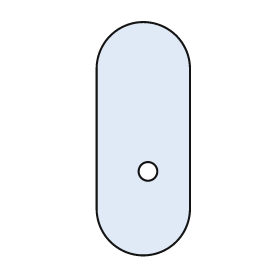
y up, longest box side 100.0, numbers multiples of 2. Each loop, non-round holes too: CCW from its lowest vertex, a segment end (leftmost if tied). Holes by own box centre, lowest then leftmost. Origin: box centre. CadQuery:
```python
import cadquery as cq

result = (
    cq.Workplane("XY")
    .moveTo(-20.0, -30.0)
    .threePointArc((0.0, -50.0), (20.0, -30.0))
    .lineTo(20.0, 30.0)
    .threePointArc((0.0, 50.0), (-20.0, 30.0))
    .close()
    .moveTo(2.0, -14.0)
    .circle(4.0)
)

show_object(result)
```